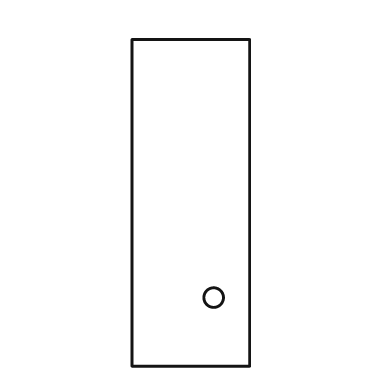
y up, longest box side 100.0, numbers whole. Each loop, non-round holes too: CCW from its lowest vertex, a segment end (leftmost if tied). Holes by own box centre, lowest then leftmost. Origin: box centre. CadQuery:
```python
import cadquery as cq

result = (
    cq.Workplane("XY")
    .moveTo(-18.0, -50.0)
    .lineTo(18.0, -50.0)
    .lineTo(18.0, 50.0)
    .lineTo(-18.0, 50.0)
    .close()
    .moveTo(7.0, -29.0)
    .circle(3.0)
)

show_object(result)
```